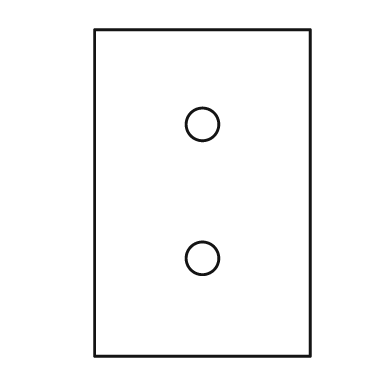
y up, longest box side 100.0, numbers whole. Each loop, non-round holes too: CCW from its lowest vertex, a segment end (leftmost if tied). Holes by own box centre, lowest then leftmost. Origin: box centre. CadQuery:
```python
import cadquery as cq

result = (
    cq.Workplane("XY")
    .moveTo(-33.0, -50.0)
    .lineTo(33.0, -50.0)
    .lineTo(33.0, 50.0)
    .lineTo(-33.0, 50.0)
    .close()
    .moveTo(0.0, -20.0)
    .circle(5.0)
    .moveTo(0.0, 21.0)
    .circle(5.0)
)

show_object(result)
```